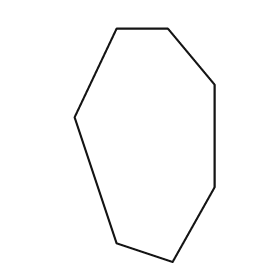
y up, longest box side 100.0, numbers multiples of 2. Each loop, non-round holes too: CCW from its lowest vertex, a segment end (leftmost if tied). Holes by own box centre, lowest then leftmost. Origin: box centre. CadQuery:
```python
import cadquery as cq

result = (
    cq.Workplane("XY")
    .moveTo(12.0, -50.0)
    .lineTo(30.0, -18.0)
    .lineTo(30.0, 26.0)
    .lineTo(10.0, 50.0)
    .lineTo(-12.0, 50.0)
    .lineTo(-30.0, 12.0)
    .lineTo(-12.0, -42.0)
    .close()
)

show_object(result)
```